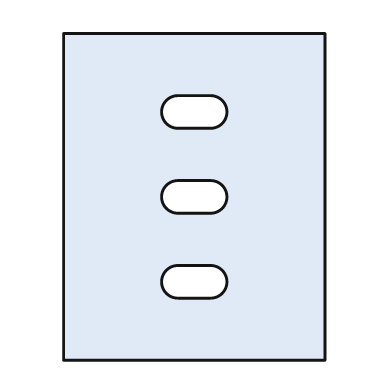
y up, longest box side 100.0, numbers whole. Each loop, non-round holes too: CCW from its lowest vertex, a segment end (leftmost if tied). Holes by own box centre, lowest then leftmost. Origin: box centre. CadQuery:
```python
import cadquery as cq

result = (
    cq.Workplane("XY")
    .moveTo(-40.0, -50.0)
    .lineTo(40.0, -50.0)
    .lineTo(40.0, 50.0)
    .lineTo(-40.0, 50.0)
    .close()
    .moveTo(-5.0, -31.0)
    .lineTo(5.0, -31.0)
    .threePointArc((10.0, -26.0), (5.0, -21.0))
    .lineTo(-5.0, -21.0)
    .threePointArc((-10.0, -26.0), (-5.0, -31.0))
    .close()
    .moveTo(-5.0, -5.0)
    .lineTo(5.0, -5.0)
    .threePointArc((10.0, 0.0), (5.0, 5.0))
    .lineTo(-5.0, 5.0)
    .threePointArc((-10.0, 0.0), (-5.0, -5.0))
    .close()
    .moveTo(-5.0, 21.0)
    .lineTo(5.0, 21.0)
    .threePointArc((10.0, 26.0), (5.0, 31.0))
    .lineTo(-5.0, 31.0)
    .threePointArc((-10.0, 26.0), (-5.0, 21.0))
    .close()
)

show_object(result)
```